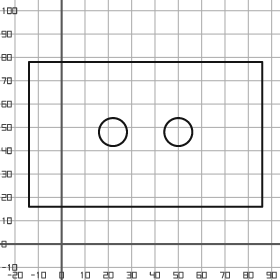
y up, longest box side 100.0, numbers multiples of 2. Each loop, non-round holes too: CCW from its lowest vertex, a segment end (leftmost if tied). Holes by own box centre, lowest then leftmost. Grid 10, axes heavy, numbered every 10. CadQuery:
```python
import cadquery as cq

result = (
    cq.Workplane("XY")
    .moveTo(-14.0, 16.0)
    .lineTo(86.0, 16.0)
    .lineTo(86.0, 78.0)
    .lineTo(-14.0, 78.0)
    .close()
    .moveTo(22.0, 48.0)
    .circle(6.0)
    .moveTo(50.0, 48.0)
    .circle(6.0)
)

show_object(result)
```